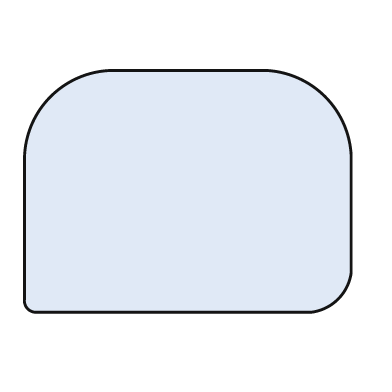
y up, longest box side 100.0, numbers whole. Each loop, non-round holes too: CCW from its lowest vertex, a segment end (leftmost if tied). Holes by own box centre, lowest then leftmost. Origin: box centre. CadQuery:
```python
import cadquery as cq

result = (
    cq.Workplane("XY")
    .moveTo(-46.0, -37.0)
    .lineTo(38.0, -37.0)
    .threePointArc((46.0, -33.0), (50.0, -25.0))
    .lineTo(50.0, 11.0)
    .threePointArc((42.0, 29.0), (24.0, 37.0))
    .lineTo(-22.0, 37.0)
    .threePointArc((-42.0, 29.0), (-50.0, 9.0))
    .lineTo(-50.0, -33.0)
    .threePointArc((-49.0, -36.0), (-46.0, -37.0))
    .close()
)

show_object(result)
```